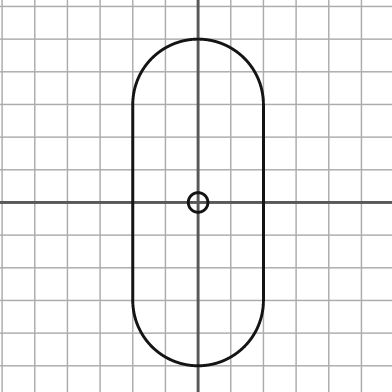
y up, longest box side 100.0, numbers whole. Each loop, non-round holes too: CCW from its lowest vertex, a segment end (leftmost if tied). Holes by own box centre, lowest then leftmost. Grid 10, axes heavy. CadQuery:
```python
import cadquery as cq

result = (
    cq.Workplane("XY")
    .moveTo(-20.0, -30.0)
    .threePointArc((0.0, -50.0), (20.0, -30.0))
    .lineTo(20.0, 30.0)
    .threePointArc((0.0, 50.0), (-20.0, 30.0))
    .close()
    .moveTo(0.0, 0.0)
    .circle(3.0)
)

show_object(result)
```